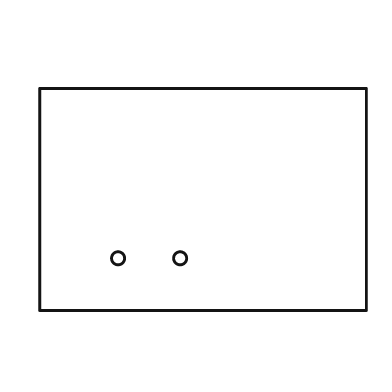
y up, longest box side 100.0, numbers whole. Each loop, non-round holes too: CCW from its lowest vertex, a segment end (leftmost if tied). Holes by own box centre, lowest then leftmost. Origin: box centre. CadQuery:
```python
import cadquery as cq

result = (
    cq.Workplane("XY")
    .moveTo(-50.0, -34.0)
    .lineTo(50.0, -34.0)
    .lineTo(50.0, 34.0)
    .lineTo(-50.0, 34.0)
    .close()
    .moveTo(-26.0, -18.0)
    .circle(2.0)
    .moveTo(-7.0, -18.0)
    .circle(2.0)
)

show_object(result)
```